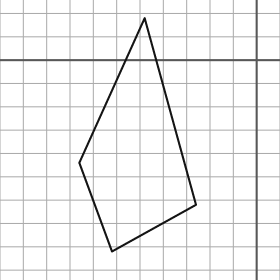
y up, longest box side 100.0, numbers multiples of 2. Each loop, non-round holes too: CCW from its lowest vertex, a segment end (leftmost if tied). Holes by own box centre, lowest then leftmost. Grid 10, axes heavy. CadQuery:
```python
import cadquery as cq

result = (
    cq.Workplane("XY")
    .moveTo(-62.0, -82.0)
    .lineTo(-26.0, -62.0)
    .lineTo(-48.0, 18.0)
    .lineTo(-76.0, -44.0)
    .close()
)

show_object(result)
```